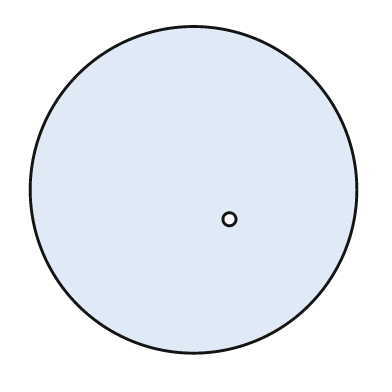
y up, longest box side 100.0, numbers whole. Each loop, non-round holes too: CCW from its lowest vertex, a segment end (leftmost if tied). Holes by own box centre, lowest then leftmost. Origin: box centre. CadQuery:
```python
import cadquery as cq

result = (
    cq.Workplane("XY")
    .moveTo(0.0, 0.0)
    .circle(50.0)
    .moveTo(11.0, -9.0)
    .circle(2.0)
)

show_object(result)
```